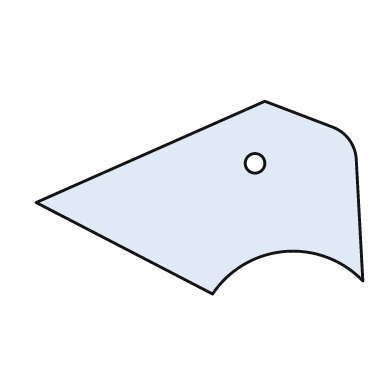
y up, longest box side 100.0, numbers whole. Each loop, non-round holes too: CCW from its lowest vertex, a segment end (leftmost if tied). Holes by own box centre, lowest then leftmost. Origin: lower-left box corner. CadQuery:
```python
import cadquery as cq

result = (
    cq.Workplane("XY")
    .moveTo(54.0, 0.0)
    .threePointArc((76.0, 13.0), (100.0, 4.0))
    .lineTo(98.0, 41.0)
    .threePointArc((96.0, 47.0), (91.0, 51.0))
    .lineTo(70.0, 59.0)
    .lineTo(0.0, 28.0)
    .close()
    .moveTo(67.0, 40.0)
    .circle(3.0)
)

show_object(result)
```